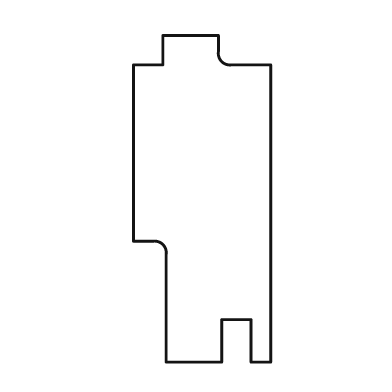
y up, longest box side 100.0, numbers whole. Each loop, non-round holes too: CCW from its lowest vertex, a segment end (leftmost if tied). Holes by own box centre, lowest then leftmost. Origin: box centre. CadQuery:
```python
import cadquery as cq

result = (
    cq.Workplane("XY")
    .moveTo(-11.0, -50.0)
    .lineTo(6.0, -50.0)
    .lineTo(6.0, -37.0)
    .lineTo(15.0, -37.0)
    .lineTo(15.0, -50.0)
    .lineTo(21.0, -50.0)
    .lineTo(21.0, 41.0)
    .lineTo(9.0, 41.0)
    .threePointArc((6.0, 42.0), (5.0, 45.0))
    .lineTo(5.0, 50.0)
    .lineTo(-12.0, 50.0)
    .lineTo(-12.0, 41.0)
    .lineTo(-21.0, 41.0)
    .lineTo(-21.0, -13.0)
    .lineTo(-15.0, -13.0)
    .threePointArc((-12.0, -14.0), (-11.0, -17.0))
    .close()
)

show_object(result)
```